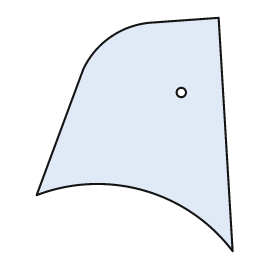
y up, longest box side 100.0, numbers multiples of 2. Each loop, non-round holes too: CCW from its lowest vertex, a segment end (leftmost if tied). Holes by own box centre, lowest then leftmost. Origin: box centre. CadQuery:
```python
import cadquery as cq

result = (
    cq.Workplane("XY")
    .moveTo(42.0, -50.0)
    .lineTo(36.0, 50.0)
    .lineTo(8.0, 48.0)
    .threePointArc((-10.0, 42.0), (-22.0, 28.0))
    .lineTo(-42.0, -26.0)
    .threePointArc((4.0, -24.0), (42.0, -50.0))
    .close()
    .moveTo(20.0, 18.0)
    .circle(2.0)
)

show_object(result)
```